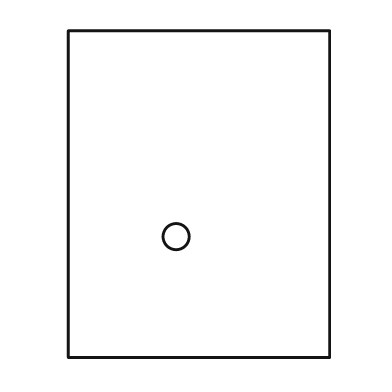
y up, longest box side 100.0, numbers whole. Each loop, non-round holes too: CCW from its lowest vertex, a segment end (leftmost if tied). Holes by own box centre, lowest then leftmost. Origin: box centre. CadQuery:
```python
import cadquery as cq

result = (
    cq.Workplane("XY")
    .moveTo(-40.0, -50.0)
    .lineTo(40.0, -50.0)
    .lineTo(40.0, 50.0)
    .lineTo(-40.0, 50.0)
    .close()
    .moveTo(-7.0, -13.0)
    .circle(4.0)
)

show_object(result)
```